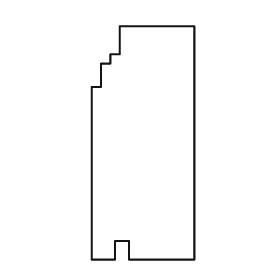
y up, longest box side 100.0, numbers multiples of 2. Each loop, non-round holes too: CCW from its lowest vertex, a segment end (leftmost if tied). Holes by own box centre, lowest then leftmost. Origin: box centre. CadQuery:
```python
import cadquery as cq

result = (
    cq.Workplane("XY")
    .moveTo(-22.0, -50.0)
    .lineTo(-12.0, -50.0)
    .lineTo(-12.0, -42.0)
    .lineTo(-6.0, -42.0)
    .lineTo(-6.0, -50.0)
    .lineTo(22.0, -50.0)
    .lineTo(22.0, 50.0)
    .lineTo(-10.0, 50.0)
    .lineTo(-10.0, 38.0)
    .lineTo(-14.0, 38.0)
    .lineTo(-14.0, 34.0)
    .lineTo(-18.0, 34.0)
    .lineTo(-18.0, 24.0)
    .lineTo(-22.0, 24.0)
    .close()
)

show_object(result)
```